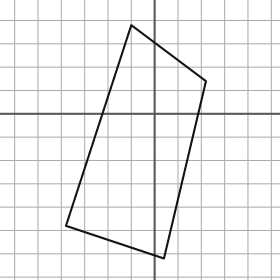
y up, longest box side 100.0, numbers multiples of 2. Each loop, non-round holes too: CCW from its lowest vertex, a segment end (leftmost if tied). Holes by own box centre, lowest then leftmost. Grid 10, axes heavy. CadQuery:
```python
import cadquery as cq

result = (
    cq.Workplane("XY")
    .moveTo(4.0, -62.0)
    .lineTo(22.0, 14.0)
    .lineTo(-10.0, 38.0)
    .lineTo(-38.0, -48.0)
    .close()
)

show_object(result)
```